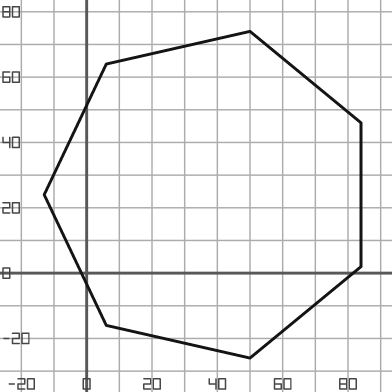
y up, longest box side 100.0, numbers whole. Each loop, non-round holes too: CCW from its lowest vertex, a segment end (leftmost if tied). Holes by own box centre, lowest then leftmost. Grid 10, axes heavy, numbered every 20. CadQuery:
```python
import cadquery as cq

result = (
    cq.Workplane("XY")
    .moveTo(50.0, -26.0)
    .lineTo(84.0, 2.0)
    .lineTo(84.0, 46.0)
    .lineTo(50.0, 74.0)
    .lineTo(6.0, 64.0)
    .lineTo(-13.0, 24.0)
    .lineTo(6.0, -16.0)
    .close()
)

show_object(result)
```